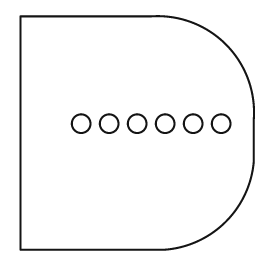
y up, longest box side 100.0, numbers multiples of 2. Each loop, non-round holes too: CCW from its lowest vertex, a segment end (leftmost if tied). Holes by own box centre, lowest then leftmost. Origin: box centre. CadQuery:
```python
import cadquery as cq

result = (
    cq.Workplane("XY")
    .moveTo(-50.0, -50.0)
    .lineTo(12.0, -50.0)
    .threePointArc((38.0, -38.0), (50.0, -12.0))
    .lineTo(50.0, 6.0)
    .threePointArc((38.0, 38.0), (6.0, 50.0))
    .lineTo(-50.0, 50.0)
    .close()
    .moveTo(-24.0, 4.0)
    .circle(4.0)
    .moveTo(-12.0, 4.0)
    .circle(4.0)
    .moveTo(0.0, 4.0)
    .circle(4.0)
    .moveTo(12.0, 4.0)
    .circle(4.0)
    .moveTo(24.0, 4.0)
    .circle(4.0)
    .moveTo(36.0, 4.0)
    .circle(4.0)
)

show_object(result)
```